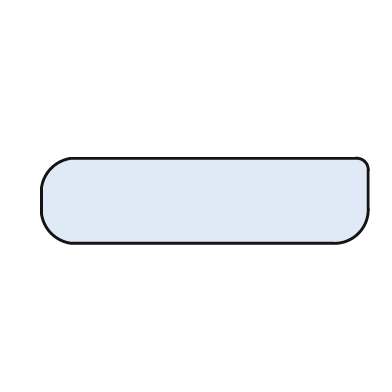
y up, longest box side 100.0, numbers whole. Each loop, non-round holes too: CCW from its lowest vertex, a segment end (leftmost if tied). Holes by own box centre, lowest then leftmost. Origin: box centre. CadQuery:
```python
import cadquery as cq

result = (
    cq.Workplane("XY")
    .moveTo(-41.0, -13.0)
    .lineTo(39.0, -13.0)
    .threePointArc((47.0, -10.0), (50.0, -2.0))
    .lineTo(50.0, 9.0)
    .threePointArc((49.0, 12.0), (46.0, 13.0))
    .lineTo(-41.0, 13.0)
    .threePointArc((-47.0, 10.0), (-50.0, 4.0))
    .lineTo(-50.0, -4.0)
    .threePointArc((-47.0, -10.0), (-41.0, -13.0))
    .close()
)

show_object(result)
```